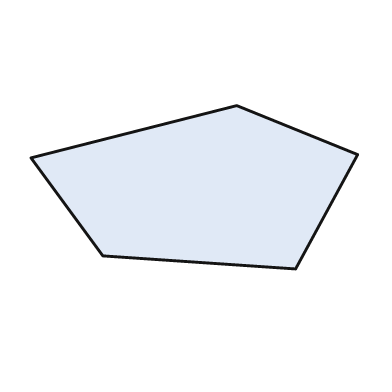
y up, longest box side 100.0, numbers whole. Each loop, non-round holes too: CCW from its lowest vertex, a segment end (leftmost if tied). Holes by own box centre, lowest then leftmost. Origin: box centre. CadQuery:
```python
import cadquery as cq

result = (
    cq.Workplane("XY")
    .moveTo(31.0, -25.0)
    .lineTo(50.0, 10.0)
    .lineTo(13.0, 25.0)
    .lineTo(-50.0, 9.0)
    .lineTo(-28.0, -21.0)
    .close()
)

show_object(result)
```